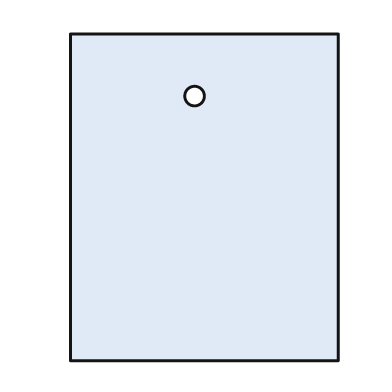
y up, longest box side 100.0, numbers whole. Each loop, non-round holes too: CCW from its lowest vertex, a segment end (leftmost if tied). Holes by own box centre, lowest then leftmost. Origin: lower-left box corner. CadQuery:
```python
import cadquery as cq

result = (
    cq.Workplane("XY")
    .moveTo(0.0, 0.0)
    .lineTo(82.0, 0.0)
    .lineTo(82.0, 100.0)
    .lineTo(0.0, 100.0)
    .close()
    .moveTo(38.0, 81.0)
    .circle(3.0)
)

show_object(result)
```